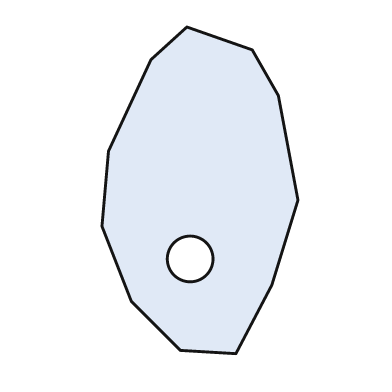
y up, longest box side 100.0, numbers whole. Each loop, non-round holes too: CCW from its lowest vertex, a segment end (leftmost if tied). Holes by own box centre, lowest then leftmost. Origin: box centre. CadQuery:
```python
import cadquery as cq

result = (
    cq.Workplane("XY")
    .moveTo(11.0, -50.0)
    .lineTo(22.0, -29.0)
    .lineTo(30.0, -3.0)
    .lineTo(24.0, 29.0)
    .lineTo(16.0, 43.0)
    .lineTo(-4.0, 50.0)
    .lineTo(-15.0, 40.0)
    .lineTo(-28.0, 12.0)
    .lineTo(-30.0, -11.0)
    .lineTo(-21.0, -34.0)
    .lineTo(-6.0, -49.0)
    .close()
    .moveTo(-3.0, -21.0)
    .circle(7.0)
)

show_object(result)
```